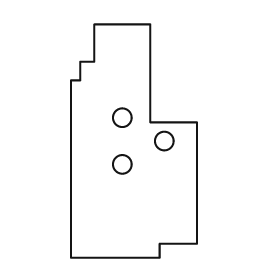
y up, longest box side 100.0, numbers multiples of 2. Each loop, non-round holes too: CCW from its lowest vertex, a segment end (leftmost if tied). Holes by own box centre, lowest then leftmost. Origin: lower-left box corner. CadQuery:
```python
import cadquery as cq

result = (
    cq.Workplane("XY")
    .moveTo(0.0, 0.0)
    .lineTo(38.0, 0.0)
    .lineTo(38.0, 6.0)
    .lineTo(54.0, 6.0)
    .lineTo(54.0, 58.0)
    .lineTo(34.0, 58.0)
    .lineTo(34.0, 100.0)
    .lineTo(10.0, 100.0)
    .lineTo(10.0, 84.0)
    .lineTo(4.0, 84.0)
    .lineTo(4.0, 76.0)
    .lineTo(0.0, 76.0)
    .close()
    .moveTo(22.0, 40.0)
    .circle(4.0)
    .moveTo(40.0, 50.0)
    .circle(4.0)
    .moveTo(22.0, 60.0)
    .circle(4.0)
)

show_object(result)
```